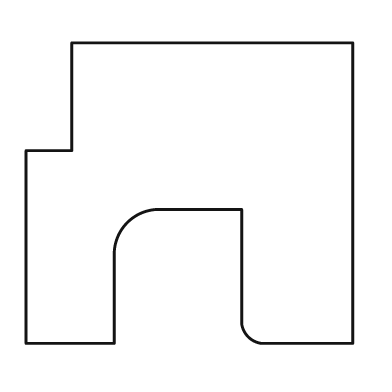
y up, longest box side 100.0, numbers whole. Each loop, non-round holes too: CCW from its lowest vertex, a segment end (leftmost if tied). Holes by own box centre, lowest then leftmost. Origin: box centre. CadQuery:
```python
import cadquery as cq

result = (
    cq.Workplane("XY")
    .moveTo(-50.0, -46.0)
    .lineTo(-23.0, -46.0)
    .lineTo(-23.0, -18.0)
    .threePointArc((-19.0, -9.0), (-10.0, -5.0))
    .lineTo(16.0, -5.0)
    .lineTo(16.0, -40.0)
    .threePointArc((18.0, -44.0), (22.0, -46.0))
    .lineTo(50.0, -46.0)
    .lineTo(50.0, 46.0)
    .lineTo(-36.0, 46.0)
    .lineTo(-36.0, 13.0)
    .lineTo(-50.0, 13.0)
    .close()
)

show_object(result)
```